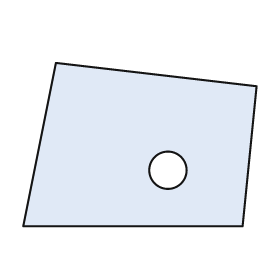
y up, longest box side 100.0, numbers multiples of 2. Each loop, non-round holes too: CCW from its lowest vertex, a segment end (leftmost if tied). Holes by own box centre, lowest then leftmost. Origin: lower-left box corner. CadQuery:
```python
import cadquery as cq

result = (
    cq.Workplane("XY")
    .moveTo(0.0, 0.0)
    .lineTo(94.0, 0.0)
    .lineTo(100.0, 60.0)
    .lineTo(14.0, 70.0)
    .close()
    .moveTo(62.0, 24.0)
    .circle(8.0)
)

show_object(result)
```